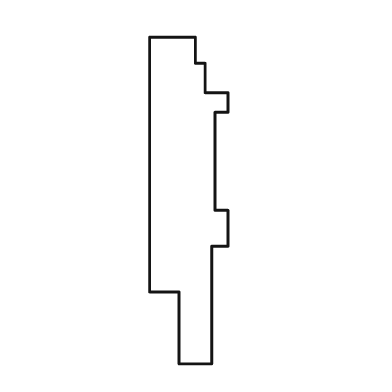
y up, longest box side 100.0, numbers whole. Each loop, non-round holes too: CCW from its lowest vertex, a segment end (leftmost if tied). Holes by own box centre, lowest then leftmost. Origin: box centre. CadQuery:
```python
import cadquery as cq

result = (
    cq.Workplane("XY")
    .moveTo(-3.0, -50.0)
    .lineTo(7.0, -50.0)
    .lineTo(7.0, -14.0)
    .lineTo(12.0, -14.0)
    .lineTo(12.0, -3.0)
    .lineTo(8.0, -3.0)
    .lineTo(8.0, 27.0)
    .lineTo(12.0, 27.0)
    .lineTo(12.0, 33.0)
    .lineTo(5.0, 33.0)
    .lineTo(5.0, 42.0)
    .lineTo(2.0, 42.0)
    .lineTo(2.0, 50.0)
    .lineTo(-12.0, 50.0)
    .lineTo(-12.0, -28.0)
    .lineTo(-3.0, -28.0)
    .close()
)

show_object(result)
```